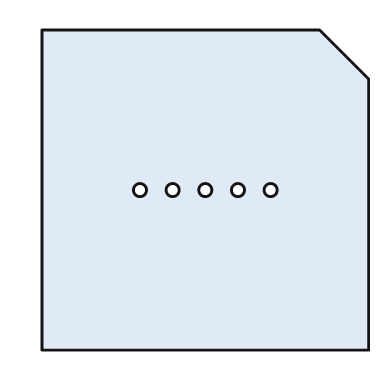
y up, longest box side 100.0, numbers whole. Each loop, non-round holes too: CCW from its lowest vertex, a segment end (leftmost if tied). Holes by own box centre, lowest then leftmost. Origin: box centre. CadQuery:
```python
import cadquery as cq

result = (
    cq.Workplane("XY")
    .moveTo(-50.0, -49.0)
    .lineTo(50.0, -49.0)
    .lineTo(50.0, 34.0)
    .lineTo(35.0, 49.0)
    .lineTo(-50.0, 49.0)
    .close()
    .moveTo(-20.0, 0.0)
    .circle(2.0)
    .moveTo(-10.0, 0.0)
    .circle(2.0)
    .moveTo(0.0, 0.0)
    .circle(2.0)
    .moveTo(10.0, 0.0)
    .circle(2.0)
    .moveTo(20.0, 0.0)
    .circle(2.0)
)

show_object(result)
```